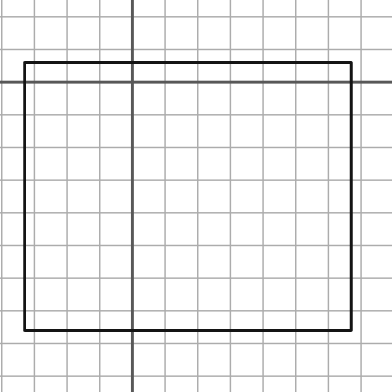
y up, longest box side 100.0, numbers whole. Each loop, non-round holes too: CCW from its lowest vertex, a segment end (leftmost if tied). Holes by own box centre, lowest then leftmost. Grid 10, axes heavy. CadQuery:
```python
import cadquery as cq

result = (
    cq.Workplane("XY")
    .moveTo(-33.0, -76.0)
    .lineTo(67.0, -76.0)
    .lineTo(67.0, 6.0)
    .lineTo(-33.0, 6.0)
    .close()
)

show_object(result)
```